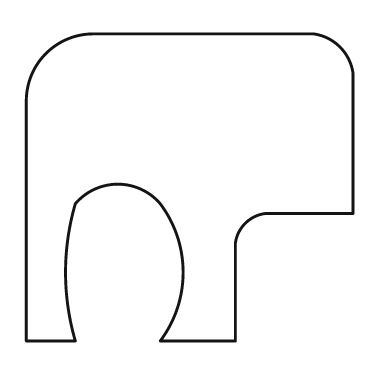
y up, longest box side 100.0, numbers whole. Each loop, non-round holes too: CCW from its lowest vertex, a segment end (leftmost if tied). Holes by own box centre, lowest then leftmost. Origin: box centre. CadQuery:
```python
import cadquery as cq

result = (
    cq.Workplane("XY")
    .moveTo(-50.0, -47.0)
    .lineTo(-35.0, -47.0)
    .threePointArc((-38.0, -26.0), (-35.0, -5.0))
    .threePointArc((-22.0, 1.0), (-9.0, -5.0))
    .threePointArc((-2.0, -26.0), (-9.0, -47.0))
    .lineTo(14.0, -47.0)
    .lineTo(14.0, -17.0)
    .threePointArc((17.0, -11.0), (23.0, -8.0))
    .lineTo(50.0, -8.0)
    .lineTo(50.0, 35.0)
    .threePointArc((46.0, 43.0), (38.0, 47.0))
    .lineTo(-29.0, 47.0)
    .threePointArc((-44.0, 41.0), (-50.0, 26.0))
    .close()
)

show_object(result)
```